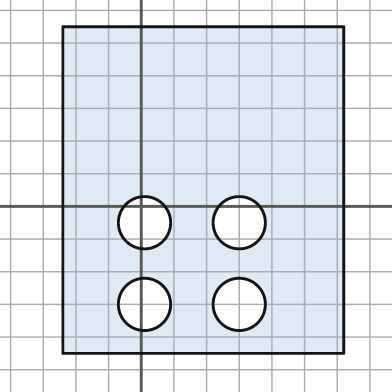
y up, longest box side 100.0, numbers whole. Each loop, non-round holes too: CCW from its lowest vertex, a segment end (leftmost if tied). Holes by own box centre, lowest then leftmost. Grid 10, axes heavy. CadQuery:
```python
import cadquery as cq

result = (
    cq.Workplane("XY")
    .moveTo(-24.0, -45.0)
    .lineTo(62.0, -45.0)
    .lineTo(62.0, 55.0)
    .lineTo(-24.0, 55.0)
    .close()
    .moveTo(1.0, -30.0)
    .circle(8.0)
    .moveTo(30.0, -30.0)
    .circle(8.0)
    .moveTo(1.0, -5.0)
    .circle(8.0)
    .moveTo(30.0, -5.0)
    .circle(8.0)
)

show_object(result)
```